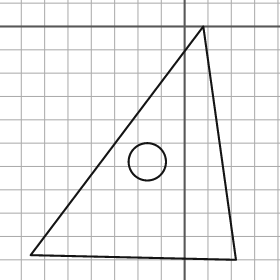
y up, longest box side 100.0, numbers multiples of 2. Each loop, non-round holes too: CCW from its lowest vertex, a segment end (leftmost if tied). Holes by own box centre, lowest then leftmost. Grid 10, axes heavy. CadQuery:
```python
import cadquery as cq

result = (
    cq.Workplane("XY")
    .moveTo(22.0, -100.0)
    .lineTo(8.0, 0.0)
    .lineTo(-66.0, -98.0)
    .close()
    .moveTo(-16.0, -58.0)
    .circle(8.0)
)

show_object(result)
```